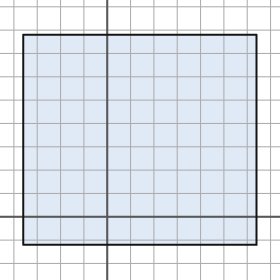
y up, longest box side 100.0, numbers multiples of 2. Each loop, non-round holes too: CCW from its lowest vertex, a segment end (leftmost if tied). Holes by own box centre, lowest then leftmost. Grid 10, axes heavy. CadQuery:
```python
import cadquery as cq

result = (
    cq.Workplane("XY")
    .moveTo(-36.0, -12.0)
    .lineTo(64.0, -12.0)
    .lineTo(64.0, 78.0)
    .lineTo(-36.0, 78.0)
    .close()
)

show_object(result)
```